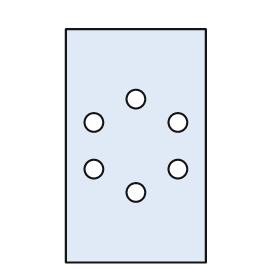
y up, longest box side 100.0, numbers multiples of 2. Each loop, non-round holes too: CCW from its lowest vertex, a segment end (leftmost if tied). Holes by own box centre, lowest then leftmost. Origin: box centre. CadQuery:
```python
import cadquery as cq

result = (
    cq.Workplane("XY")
    .moveTo(-30.0, -50.0)
    .lineTo(30.0, -50.0)
    .lineTo(30.0, 50.0)
    .lineTo(-30.0, 50.0)
    .close()
    .moveTo(0.0, -20.0)
    .circle(4.0)
    .moveTo(-18.0, -10.0)
    .circle(4.0)
    .moveTo(18.0, -10.0)
    .circle(4.0)
    .moveTo(-18.0, 10.0)
    .circle(4.0)
    .moveTo(18.0, 10.0)
    .circle(4.0)
    .moveTo(0.0, 20.0)
    .circle(4.0)
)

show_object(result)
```